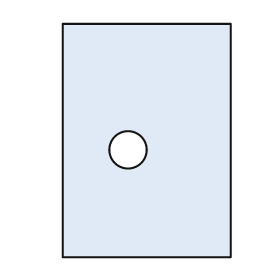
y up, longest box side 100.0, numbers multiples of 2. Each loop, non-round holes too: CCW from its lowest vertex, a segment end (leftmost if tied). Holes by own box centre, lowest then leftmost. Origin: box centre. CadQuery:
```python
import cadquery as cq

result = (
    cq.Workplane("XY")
    .moveTo(-36.0, -50.0)
    .lineTo(36.0, -50.0)
    .lineTo(36.0, 50.0)
    .lineTo(-36.0, 50.0)
    .close()
    .moveTo(-8.0, -4.0)
    .circle(8.0)
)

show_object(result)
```